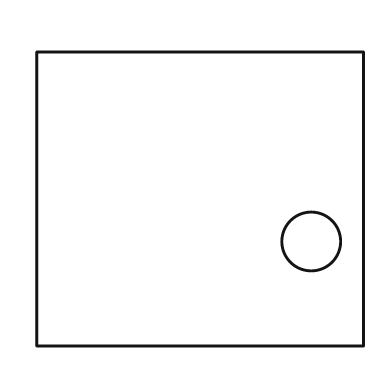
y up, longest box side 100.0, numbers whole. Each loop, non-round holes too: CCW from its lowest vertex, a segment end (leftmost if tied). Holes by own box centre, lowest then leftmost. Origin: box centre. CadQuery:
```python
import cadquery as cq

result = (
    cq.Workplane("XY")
    .moveTo(-50.0, -45.0)
    .lineTo(50.0, -45.0)
    .lineTo(50.0, 45.0)
    .lineTo(-50.0, 45.0)
    .close()
    .moveTo(34.0, -13.0)
    .circle(9.0)
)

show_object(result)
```